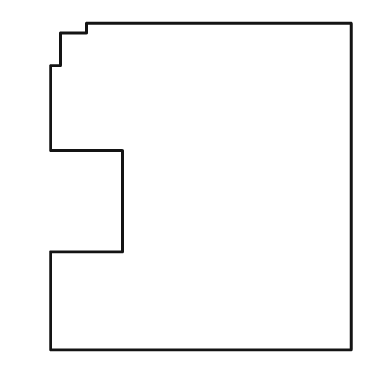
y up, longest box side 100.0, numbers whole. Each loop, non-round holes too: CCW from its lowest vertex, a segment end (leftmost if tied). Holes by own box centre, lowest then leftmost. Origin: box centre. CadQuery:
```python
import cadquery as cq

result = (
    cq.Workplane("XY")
    .moveTo(-46.0, -50.0)
    .lineTo(46.0, -50.0)
    .lineTo(46.0, 50.0)
    .lineTo(-35.0, 50.0)
    .lineTo(-35.0, 47.0)
    .lineTo(-43.0, 47.0)
    .lineTo(-43.0, 37.0)
    .lineTo(-46.0, 37.0)
    .lineTo(-46.0, 11.0)
    .lineTo(-24.0, 11.0)
    .lineTo(-24.0, -20.0)
    .lineTo(-46.0, -20.0)
    .close()
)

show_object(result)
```